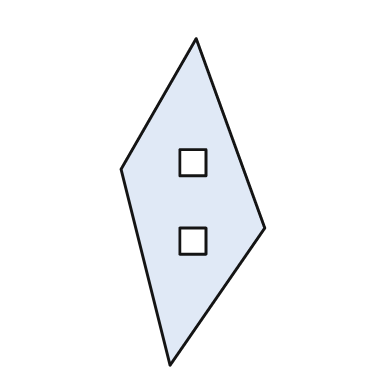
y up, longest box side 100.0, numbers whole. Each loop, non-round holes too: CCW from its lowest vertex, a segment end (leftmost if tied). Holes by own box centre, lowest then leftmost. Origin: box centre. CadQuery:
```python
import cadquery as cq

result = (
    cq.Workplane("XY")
    .moveTo(-7.0, -50.0)
    .lineTo(22.0, -8.0)
    .lineTo(1.0, 50.0)
    .lineTo(-22.0, 10.0)
    .close()
    .moveTo(-4.0, -16.0)
    .lineTo(4.0, -16.0)
    .lineTo(4.0, -8.0)
    .lineTo(-4.0, -8.0)
    .close()
    .moveTo(-4.0, 8.0)
    .lineTo(4.0, 8.0)
    .lineTo(4.0, 16.0)
    .lineTo(-4.0, 16.0)
    .close()
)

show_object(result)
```